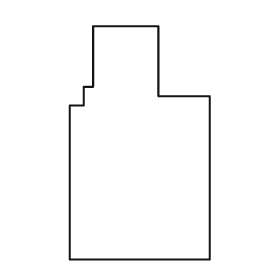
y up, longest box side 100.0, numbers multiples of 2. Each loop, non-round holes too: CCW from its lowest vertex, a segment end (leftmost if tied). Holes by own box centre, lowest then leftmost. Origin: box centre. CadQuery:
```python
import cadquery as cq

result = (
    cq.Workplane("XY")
    .moveTo(-30.0, -50.0)
    .lineTo(30.0, -50.0)
    .lineTo(30.0, 20.0)
    .lineTo(8.0, 20.0)
    .lineTo(8.0, 50.0)
    .lineTo(-20.0, 50.0)
    .lineTo(-20.0, 24.0)
    .lineTo(-24.0, 24.0)
    .lineTo(-24.0, 16.0)
    .lineTo(-30.0, 16.0)
    .close()
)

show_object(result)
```